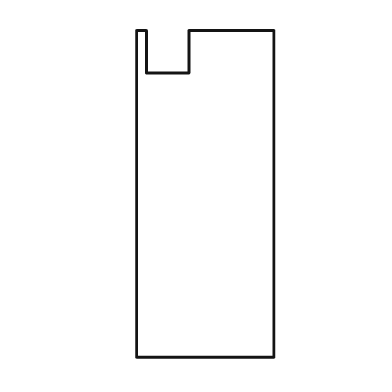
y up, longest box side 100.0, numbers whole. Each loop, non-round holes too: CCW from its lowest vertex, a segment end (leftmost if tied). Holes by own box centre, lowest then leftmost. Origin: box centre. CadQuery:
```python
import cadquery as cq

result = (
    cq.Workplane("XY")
    .moveTo(-21.0, -50.0)
    .lineTo(21.0, -50.0)
    .lineTo(21.0, 50.0)
    .lineTo(-5.0, 50.0)
    .lineTo(-5.0, 37.0)
    .lineTo(-18.0, 37.0)
    .lineTo(-18.0, 50.0)
    .lineTo(-21.0, 50.0)
    .close()
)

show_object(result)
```